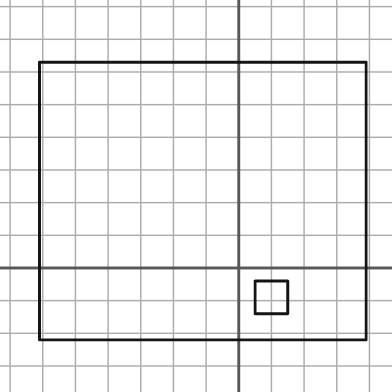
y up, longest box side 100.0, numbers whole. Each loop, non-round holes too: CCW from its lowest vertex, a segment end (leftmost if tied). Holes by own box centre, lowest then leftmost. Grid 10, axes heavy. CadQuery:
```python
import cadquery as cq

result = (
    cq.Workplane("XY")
    .moveTo(-61.0, -22.0)
    .lineTo(39.0, -22.0)
    .lineTo(39.0, 63.0)
    .lineTo(-61.0, 63.0)
    .close()
    .moveTo(5.0, -14.0)
    .lineTo(15.0, -14.0)
    .lineTo(15.0, -4.0)
    .lineTo(5.0, -4.0)
    .close()
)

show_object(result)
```